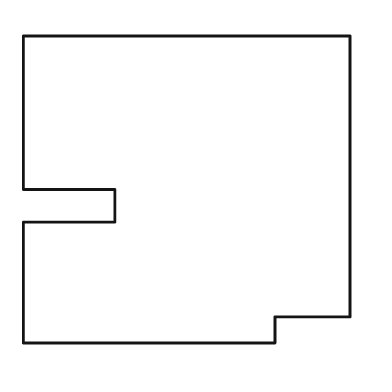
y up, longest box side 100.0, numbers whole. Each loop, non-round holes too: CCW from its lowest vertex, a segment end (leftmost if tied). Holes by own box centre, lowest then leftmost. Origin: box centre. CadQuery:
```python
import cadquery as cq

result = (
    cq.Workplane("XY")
    .moveTo(-50.0, -47.0)
    .lineTo(27.0, -47.0)
    .lineTo(27.0, -39.0)
    .lineTo(50.0, -39.0)
    .lineTo(50.0, 47.0)
    .lineTo(-50.0, 47.0)
    .lineTo(-50.0, 0.0)
    .lineTo(-22.0, 0.0)
    .lineTo(-22.0, -10.0)
    .lineTo(-50.0, -10.0)
    .close()
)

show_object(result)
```